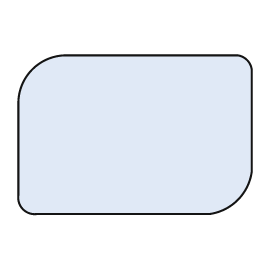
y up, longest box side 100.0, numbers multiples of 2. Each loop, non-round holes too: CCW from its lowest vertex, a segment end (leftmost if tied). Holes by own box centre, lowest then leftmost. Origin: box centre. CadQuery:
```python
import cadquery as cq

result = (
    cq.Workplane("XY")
    .moveTo(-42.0, -34.0)
    .lineTo(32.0, -34.0)
    .threePointArc((44.0, -28.0), (50.0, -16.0))
    .lineTo(50.0, 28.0)
    .threePointArc((48.0, 32.0), (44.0, 34.0))
    .lineTo(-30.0, 34.0)
    .threePointArc((-44.0, 28.0), (-50.0, 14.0))
    .lineTo(-50.0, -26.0)
    .threePointArc((-48.0, -32.0), (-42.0, -34.0))
    .close()
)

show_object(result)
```